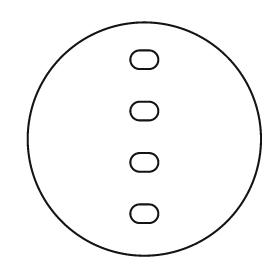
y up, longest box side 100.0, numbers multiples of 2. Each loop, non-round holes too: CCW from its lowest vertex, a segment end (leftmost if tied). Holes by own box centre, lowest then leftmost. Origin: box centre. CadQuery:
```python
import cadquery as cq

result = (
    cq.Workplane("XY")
    .moveTo(0.0, 0.0)
    .circle(50.0)
    .moveTo(-2.0, -36.0)
    .lineTo(2.0, -36.0)
    .threePointArc((6.0, -32.0), (2.0, -28.0))
    .lineTo(-2.0, -28.0)
    .threePointArc((-6.0, -32.0), (-2.0, -36.0))
    .close()
    .moveTo(-2.0, -14.0)
    .lineTo(2.0, -14.0)
    .threePointArc((6.0, -10.0), (2.0, -6.0))
    .lineTo(-2.0, -6.0)
    .threePointArc((-6.0, -10.0), (-2.0, -14.0))
    .close()
    .moveTo(-2.0, 8.0)
    .lineTo(2.0, 8.0)
    .threePointArc((6.0, 12.0), (2.0, 16.0))
    .lineTo(-2.0, 16.0)
    .threePointArc((-6.0, 12.0), (-2.0, 8.0))
    .close()
    .moveTo(-2.0, 30.0)
    .lineTo(2.0, 30.0)
    .threePointArc((6.0, 34.0), (2.0, 38.0))
    .lineTo(-2.0, 38.0)
    .threePointArc((-6.0, 34.0), (-2.0, 30.0))
    .close()
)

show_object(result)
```